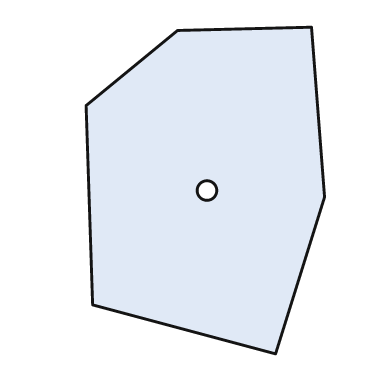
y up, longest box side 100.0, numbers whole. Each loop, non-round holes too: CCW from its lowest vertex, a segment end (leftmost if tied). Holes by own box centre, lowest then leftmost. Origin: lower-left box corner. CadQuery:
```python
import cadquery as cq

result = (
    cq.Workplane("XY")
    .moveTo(58.0, 0.0)
    .lineTo(73.0, 48.0)
    .lineTo(69.0, 100.0)
    .lineTo(28.0, 99.0)
    .lineTo(0.0, 76.0)
    .lineTo(2.0, 15.0)
    .close()
    .moveTo(37.0, 50.0)
    .circle(3.0)
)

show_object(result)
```